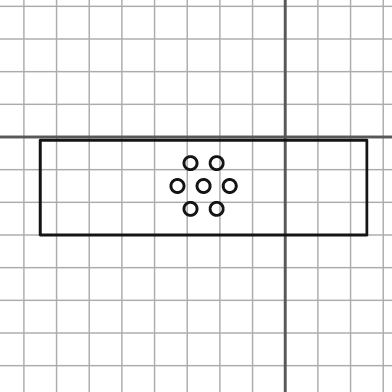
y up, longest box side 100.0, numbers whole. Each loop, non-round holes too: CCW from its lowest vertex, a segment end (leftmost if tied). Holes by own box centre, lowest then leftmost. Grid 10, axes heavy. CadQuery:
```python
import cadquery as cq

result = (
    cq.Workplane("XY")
    .moveTo(-75.0, -30.0)
    .lineTo(25.0, -30.0)
    .lineTo(25.0, -1.0)
    .lineTo(-75.0, -1.0)
    .close()
    .moveTo(-29.0, -22.0)
    .circle(2.0)
    .moveTo(-21.0, -22.0)
    .circle(2.0)
    .moveTo(-33.0, -15.0)
    .circle(2.0)
    .moveTo(-25.0, -15.0)
    .circle(2.0)
    .moveTo(-17.0, -15.0)
    .circle(2.0)
    .moveTo(-29.0, -8.0)
    .circle(2.0)
    .moveTo(-21.0, -8.0)
    .circle(2.0)
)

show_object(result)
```